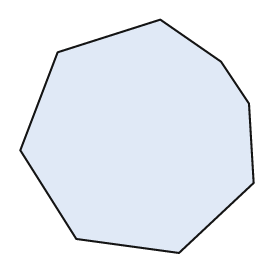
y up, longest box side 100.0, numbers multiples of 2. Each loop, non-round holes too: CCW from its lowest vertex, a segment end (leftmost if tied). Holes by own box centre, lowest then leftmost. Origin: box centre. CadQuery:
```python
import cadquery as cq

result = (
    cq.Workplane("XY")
    .moveTo(18.0, -50.0)
    .lineTo(50.0, -20.0)
    .lineTo(48.0, 14.0)
    .lineTo(36.0, 32.0)
    .lineTo(10.0, 50.0)
    .lineTo(-34.0, 36.0)
    .lineTo(-50.0, -6.0)
    .lineTo(-26.0, -44.0)
    .close()
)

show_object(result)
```